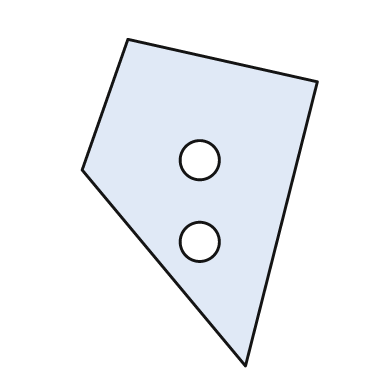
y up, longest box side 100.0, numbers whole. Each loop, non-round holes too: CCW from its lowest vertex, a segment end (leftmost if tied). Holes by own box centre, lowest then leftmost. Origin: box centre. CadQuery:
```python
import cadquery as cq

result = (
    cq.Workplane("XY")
    .moveTo(14.0, -50.0)
    .lineTo(36.0, 37.0)
    .lineTo(-22.0, 50.0)
    .lineTo(-36.0, 10.0)
    .close()
    .moveTo(0.0, -12.0)
    .circle(6.0)
    .moveTo(0.0, 13.0)
    .circle(6.0)
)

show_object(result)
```